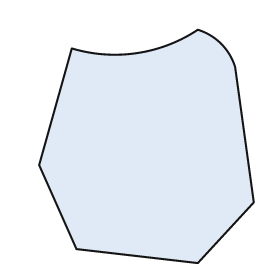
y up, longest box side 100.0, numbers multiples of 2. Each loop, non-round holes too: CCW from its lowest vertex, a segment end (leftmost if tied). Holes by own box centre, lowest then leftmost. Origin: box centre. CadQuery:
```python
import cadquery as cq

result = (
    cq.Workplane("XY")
    .moveTo(22.0, -50.0)
    .lineTo(46.0, -24.0)
    .lineTo(38.0, 34.0)
    .threePointArc((32.0, 44.0), (22.0, 50.0))
    .threePointArc((-4.0, 40.0), (-32.0, 42.0))
    .lineTo(-46.0, -8.0)
    .lineTo(-30.0, -44.0)
    .close()
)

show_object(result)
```